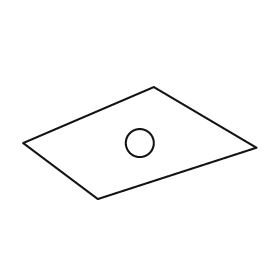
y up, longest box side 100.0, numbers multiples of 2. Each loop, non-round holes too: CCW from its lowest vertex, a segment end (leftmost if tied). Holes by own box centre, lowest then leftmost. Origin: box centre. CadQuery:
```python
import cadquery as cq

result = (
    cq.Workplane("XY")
    .moveTo(-18.0, -24.0)
    .lineTo(50.0, -2.0)
    .lineTo(6.0, 24.0)
    .lineTo(-50.0, 0.0)
    .close()
    .moveTo(0.0, 0.0)
    .circle(6.0)
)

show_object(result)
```